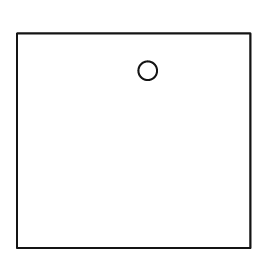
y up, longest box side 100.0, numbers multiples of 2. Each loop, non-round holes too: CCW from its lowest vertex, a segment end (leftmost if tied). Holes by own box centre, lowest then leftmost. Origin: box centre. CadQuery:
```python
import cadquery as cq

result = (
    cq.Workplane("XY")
    .moveTo(-50.0, -46.0)
    .lineTo(50.0, -46.0)
    .lineTo(50.0, 46.0)
    .lineTo(-50.0, 46.0)
    .close()
    .moveTo(6.0, 30.0)
    .circle(4.0)
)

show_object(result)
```